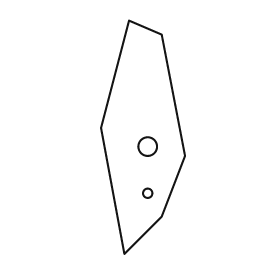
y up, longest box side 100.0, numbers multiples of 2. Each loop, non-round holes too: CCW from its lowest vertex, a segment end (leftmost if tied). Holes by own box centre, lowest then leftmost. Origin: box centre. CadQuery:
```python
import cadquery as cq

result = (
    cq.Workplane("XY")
    .moveTo(-8.0, -50.0)
    .lineTo(8.0, -34.0)
    .lineTo(18.0, -8.0)
    .lineTo(8.0, 44.0)
    .lineTo(-6.0, 50.0)
    .lineTo(-18.0, 4.0)
    .close()
    .moveTo(2.0, -24.0)
    .circle(2.0)
    .moveTo(2.0, -4.0)
    .circle(4.0)
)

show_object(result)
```